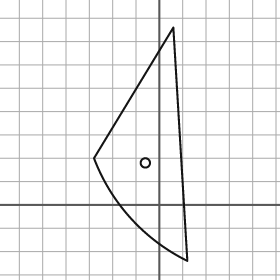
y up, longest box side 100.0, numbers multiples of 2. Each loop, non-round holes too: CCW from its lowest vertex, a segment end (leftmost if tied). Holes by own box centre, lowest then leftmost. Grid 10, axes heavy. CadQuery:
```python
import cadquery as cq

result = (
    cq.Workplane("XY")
    .moveTo(12.0, -24.0)
    .lineTo(6.0, 76.0)
    .lineTo(-28.0, 20.0)
    .threePointArc((-12.0, -6.0), (12.0, -24.0))
    .close()
    .moveTo(-6.0, 18.0)
    .circle(2.0)
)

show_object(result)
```